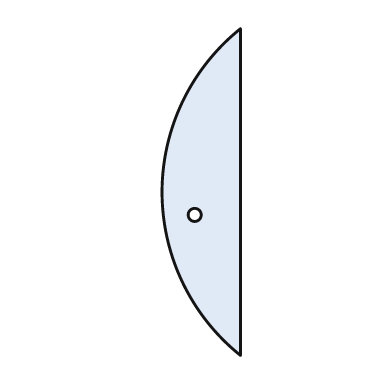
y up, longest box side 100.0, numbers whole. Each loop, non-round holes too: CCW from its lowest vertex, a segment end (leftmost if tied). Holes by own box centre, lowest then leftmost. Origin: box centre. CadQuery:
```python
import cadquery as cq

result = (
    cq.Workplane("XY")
    .moveTo(12.0, -50.0)
    .lineTo(12.0, 50.0)
    .threePointArc((-12.0, 0.0), (12.0, -50.0))
    .close()
    .moveTo(-2.0, -7.0)
    .circle(2.0)
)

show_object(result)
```